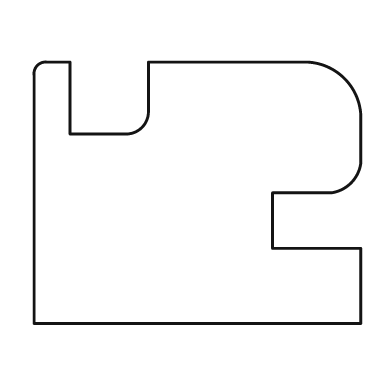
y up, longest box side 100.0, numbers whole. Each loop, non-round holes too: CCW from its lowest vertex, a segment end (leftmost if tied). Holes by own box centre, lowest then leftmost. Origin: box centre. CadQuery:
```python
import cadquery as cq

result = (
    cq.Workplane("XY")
    .moveTo(-50.0, -40.0)
    .lineTo(50.0, -40.0)
    .lineTo(50.0, -17.0)
    .lineTo(23.0, -17.0)
    .lineTo(23.0, 0.0)
    .lineTo(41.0, 0.0)
    .threePointArc((47.0, 3.0), (50.0, 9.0))
    .lineTo(50.0, 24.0)
    .threePointArc((45.0, 35.0), (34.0, 40.0))
    .lineTo(-15.0, 40.0)
    .lineTo(-15.0, 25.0)
    .threePointArc((-17.0, 20.0), (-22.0, 18.0))
    .lineTo(-39.0, 18.0)
    .lineTo(-39.0, 40.0)
    .lineTo(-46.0, 40.0)
    .threePointArc((-49.0, 39.0), (-50.0, 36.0))
    .close()
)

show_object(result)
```